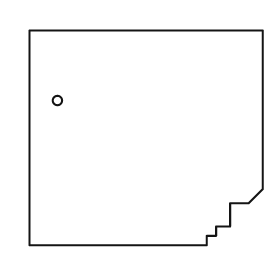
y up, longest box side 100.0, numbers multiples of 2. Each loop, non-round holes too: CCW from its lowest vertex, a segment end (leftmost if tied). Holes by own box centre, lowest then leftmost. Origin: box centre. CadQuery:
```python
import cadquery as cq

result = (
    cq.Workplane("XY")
    .moveTo(-50.0, -46.0)
    .lineTo(26.0, -46.0)
    .lineTo(26.0, -42.0)
    .lineTo(30.0, -42.0)
    .lineTo(30.0, -38.0)
    .lineTo(36.0, -38.0)
    .lineTo(36.0, -28.0)
    .lineTo(44.0, -28.0)
    .lineTo(50.0, -22.0)
    .lineTo(50.0, 46.0)
    .lineTo(-50.0, 46.0)
    .close()
    .moveTo(-38.0, 16.0)
    .circle(2.0)
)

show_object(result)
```